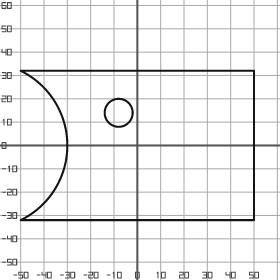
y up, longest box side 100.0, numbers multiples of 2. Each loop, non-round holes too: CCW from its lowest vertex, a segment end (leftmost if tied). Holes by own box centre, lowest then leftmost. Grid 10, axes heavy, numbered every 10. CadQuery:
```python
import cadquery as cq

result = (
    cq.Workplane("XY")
    .moveTo(-50.0, -32.0)
    .lineTo(50.0, -32.0)
    .lineTo(50.0, 32.0)
    .lineTo(-50.0, 32.0)
    .threePointArc((-30.0, 0.0), (-50.0, -32.0))
    .close()
    .moveTo(-8.0, 14.0)
    .circle(6.0)
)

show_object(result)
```